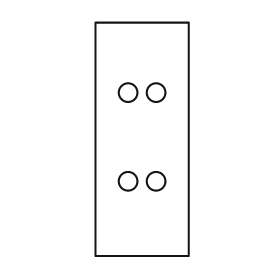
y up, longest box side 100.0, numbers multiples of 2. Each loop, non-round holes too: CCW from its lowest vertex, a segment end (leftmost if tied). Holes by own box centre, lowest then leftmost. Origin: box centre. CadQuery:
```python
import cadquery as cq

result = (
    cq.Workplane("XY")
    .moveTo(-20.0, -50.0)
    .lineTo(20.0, -50.0)
    .lineTo(20.0, 50.0)
    .lineTo(-20.0, 50.0)
    .close()
    .moveTo(-6.0, -18.0)
    .circle(4.0)
    .moveTo(6.0, -18.0)
    .circle(4.0)
    .moveTo(-6.0, 20.0)
    .circle(4.0)
    .moveTo(6.0, 20.0)
    .circle(4.0)
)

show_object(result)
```